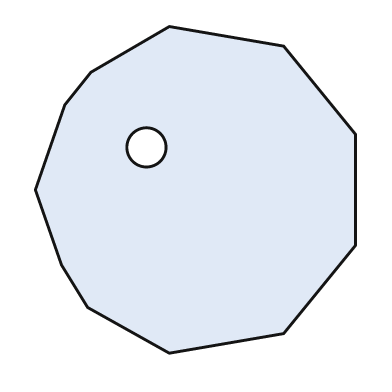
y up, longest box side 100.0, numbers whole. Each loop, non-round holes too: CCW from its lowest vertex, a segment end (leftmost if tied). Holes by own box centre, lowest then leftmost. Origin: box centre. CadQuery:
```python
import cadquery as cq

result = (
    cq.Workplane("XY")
    .moveTo(-8.0, -50.0)
    .lineTo(27.0, -44.0)
    .lineTo(49.0, -17.0)
    .lineTo(49.0, 17.0)
    .lineTo(27.0, 44.0)
    .lineTo(-8.0, 50.0)
    .lineTo(-32.0, 36.0)
    .lineTo(-40.0, 26.0)
    .lineTo(-49.0, 0.0)
    .lineTo(-41.0, -23.0)
    .lineTo(-33.0, -36.0)
    .close()
    .moveTo(-15.0, 13.0)
    .circle(6.0)
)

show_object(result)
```